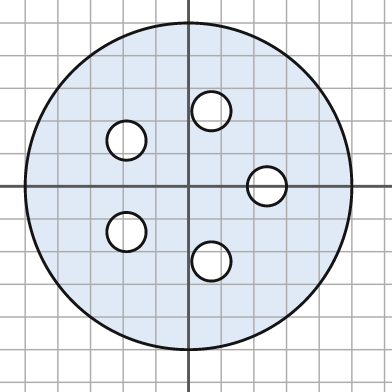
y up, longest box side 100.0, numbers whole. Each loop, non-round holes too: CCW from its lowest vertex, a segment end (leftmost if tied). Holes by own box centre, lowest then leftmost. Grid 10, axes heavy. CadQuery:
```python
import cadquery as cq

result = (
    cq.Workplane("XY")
    .moveTo(0.0, 0.0)
    .circle(50.0)
    .moveTo(7.0, -23.0)
    .circle(6.0)
    .moveTo(-19.0, -14.0)
    .circle(6.0)
    .moveTo(24.0, 0.0)
    .circle(6.0)
    .moveTo(-19.0, 14.0)
    .circle(6.0)
    .moveTo(7.0, 23.0)
    .circle(6.0)
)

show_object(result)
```